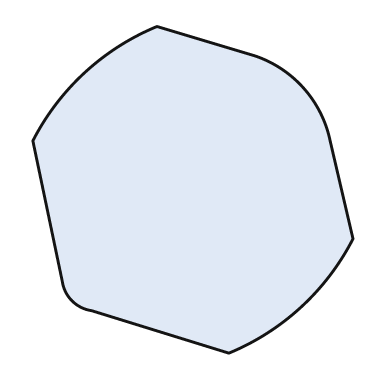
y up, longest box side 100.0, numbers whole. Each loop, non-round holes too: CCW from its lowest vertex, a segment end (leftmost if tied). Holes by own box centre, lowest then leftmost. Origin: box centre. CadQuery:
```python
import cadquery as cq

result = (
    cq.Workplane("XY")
    .moveTo(11.0, -50.0)
    .threePointArc((33.0, -36.0), (49.0, -15.0))
    .lineTo(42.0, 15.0)
    .threePointArc((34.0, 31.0), (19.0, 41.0))
    .lineTo(-11.0, 50.0)
    .threePointArc((-33.0, 36.0), (-49.0, 15.0))
    .lineTo(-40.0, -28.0)
    .threePointArc((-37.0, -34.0), (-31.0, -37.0))
    .close()
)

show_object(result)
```